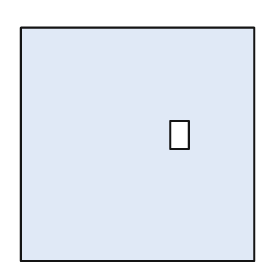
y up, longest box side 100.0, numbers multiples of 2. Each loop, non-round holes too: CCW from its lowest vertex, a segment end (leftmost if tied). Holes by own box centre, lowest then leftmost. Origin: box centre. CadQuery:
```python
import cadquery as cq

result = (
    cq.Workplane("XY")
    .moveTo(-50.0, -50.0)
    .lineTo(50.0, -50.0)
    .lineTo(50.0, 50.0)
    .lineTo(-50.0, 50.0)
    .close()
    .moveTo(14.0, -2.0)
    .lineTo(22.0, -2.0)
    .lineTo(22.0, 10.0)
    .lineTo(14.0, 10.0)
    .close()
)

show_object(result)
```